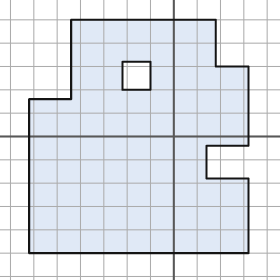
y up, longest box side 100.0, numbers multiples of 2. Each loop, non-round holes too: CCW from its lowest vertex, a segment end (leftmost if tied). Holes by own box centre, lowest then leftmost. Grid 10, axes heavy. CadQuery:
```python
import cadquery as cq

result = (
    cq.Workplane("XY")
    .moveTo(-62.0, -50.0)
    .lineTo(32.0, -50.0)
    .lineTo(32.0, -18.0)
    .lineTo(14.0, -18.0)
    .lineTo(14.0, -4.0)
    .lineTo(32.0, -4.0)
    .lineTo(32.0, 30.0)
    .lineTo(18.0, 30.0)
    .lineTo(18.0, 50.0)
    .lineTo(-44.0, 50.0)
    .lineTo(-44.0, 16.0)
    .lineTo(-62.0, 16.0)
    .close()
    .moveTo(-22.0, 20.0)
    .lineTo(-10.0, 20.0)
    .lineTo(-10.0, 32.0)
    .lineTo(-22.0, 32.0)
    .close()
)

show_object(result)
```